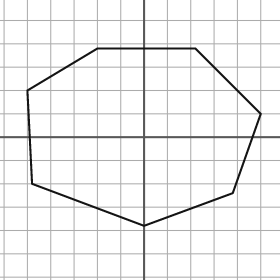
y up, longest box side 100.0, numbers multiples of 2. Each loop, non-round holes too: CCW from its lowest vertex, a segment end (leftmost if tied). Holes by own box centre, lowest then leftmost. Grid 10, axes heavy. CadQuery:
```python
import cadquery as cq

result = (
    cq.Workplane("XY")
    .moveTo(0.0, -38.0)
    .lineTo(38.0, -24.0)
    .lineTo(50.0, 10.0)
    .lineTo(22.0, 38.0)
    .lineTo(-20.0, 38.0)
    .lineTo(-50.0, 20.0)
    .lineTo(-48.0, -20.0)
    .close()
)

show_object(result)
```